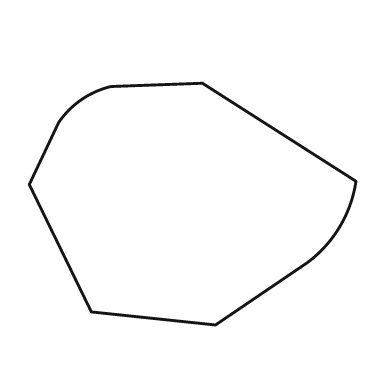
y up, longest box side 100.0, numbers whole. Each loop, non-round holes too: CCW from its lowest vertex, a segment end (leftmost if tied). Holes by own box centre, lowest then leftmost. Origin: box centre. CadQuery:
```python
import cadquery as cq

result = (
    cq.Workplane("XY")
    .moveTo(7.0, -37.0)
    .lineTo(35.0, -18.0)
    .threePointArc((45.0, -7.0), (50.0, 7.0))
    .lineTo(3.0, 37.0)
    .lineTo(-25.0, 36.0)
    .threePointArc((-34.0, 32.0), (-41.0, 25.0))
    .lineTo(-50.0, 6.0)
    .lineTo(-31.0, -33.0)
    .close()
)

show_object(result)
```